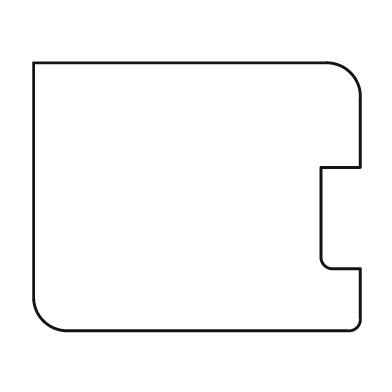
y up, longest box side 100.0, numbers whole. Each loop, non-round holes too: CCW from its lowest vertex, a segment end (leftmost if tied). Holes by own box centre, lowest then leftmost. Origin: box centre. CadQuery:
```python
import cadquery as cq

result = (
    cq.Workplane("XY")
    .moveTo(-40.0, -41.0)
    .lineTo(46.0, -41.0)
    .threePointArc((49.0, -40.0), (50.0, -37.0))
    .lineTo(50.0, -22.0)
    .lineTo(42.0, -22.0)
    .threePointArc((39.0, -21.0), (38.0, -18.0))
    .lineTo(38.0, 9.0)
    .lineTo(50.0, 9.0)
    .lineTo(50.0, 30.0)
    .threePointArc((47.0, 38.0), (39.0, 41.0))
    .lineTo(-50.0, 41.0)
    .lineTo(-50.0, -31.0)
    .threePointArc((-47.0, -38.0), (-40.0, -41.0))
    .close()
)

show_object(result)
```